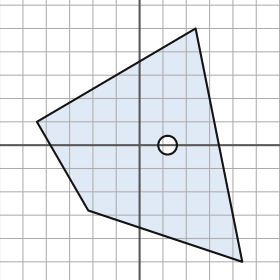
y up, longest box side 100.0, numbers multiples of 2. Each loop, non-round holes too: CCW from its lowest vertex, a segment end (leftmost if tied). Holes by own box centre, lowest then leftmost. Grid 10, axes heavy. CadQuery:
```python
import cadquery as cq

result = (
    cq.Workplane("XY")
    .moveTo(44.0, -50.0)
    .lineTo(24.0, 50.0)
    .lineTo(-44.0, 10.0)
    .lineTo(-22.0, -28.0)
    .close()
    .moveTo(12.0, 0.0)
    .circle(4.0)
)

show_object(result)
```